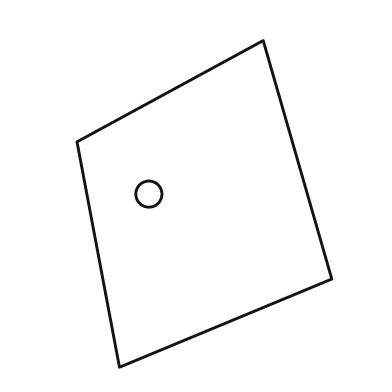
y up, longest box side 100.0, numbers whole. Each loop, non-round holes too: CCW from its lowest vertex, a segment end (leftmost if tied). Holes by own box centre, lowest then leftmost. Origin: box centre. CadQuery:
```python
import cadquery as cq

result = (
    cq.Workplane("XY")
    .moveTo(-26.0, -50.0)
    .lineTo(39.0, -23.0)
    .lineTo(18.0, 50.0)
    .lineTo(-39.0, 19.0)
    .close()
    .moveTo(-17.0, 3.0)
    .circle(4.0)
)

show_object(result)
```